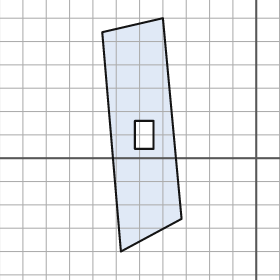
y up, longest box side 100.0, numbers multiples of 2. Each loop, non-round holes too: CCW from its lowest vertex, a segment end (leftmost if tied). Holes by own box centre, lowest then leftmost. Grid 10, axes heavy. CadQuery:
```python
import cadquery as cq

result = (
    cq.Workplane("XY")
    .moveTo(-58.0, -40.0)
    .lineTo(-32.0, -26.0)
    .lineTo(-40.0, 60.0)
    .lineTo(-66.0, 54.0)
    .close()
    .moveTo(-52.0, 4.0)
    .lineTo(-44.0, 4.0)
    .lineTo(-44.0, 16.0)
    .lineTo(-52.0, 16.0)
    .close()
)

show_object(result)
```